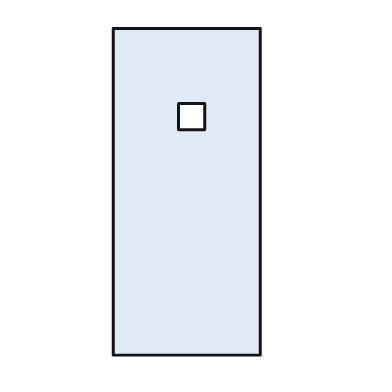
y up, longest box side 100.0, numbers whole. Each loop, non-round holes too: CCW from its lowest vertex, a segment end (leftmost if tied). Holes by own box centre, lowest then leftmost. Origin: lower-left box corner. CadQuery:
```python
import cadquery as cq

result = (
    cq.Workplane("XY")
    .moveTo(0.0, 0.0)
    .lineTo(45.0, 0.0)
    .lineTo(45.0, 100.0)
    .lineTo(0.0, 100.0)
    .close()
    .moveTo(20.0, 69.0)
    .lineTo(28.0, 69.0)
    .lineTo(28.0, 77.0)
    .lineTo(20.0, 77.0)
    .close()
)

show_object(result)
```